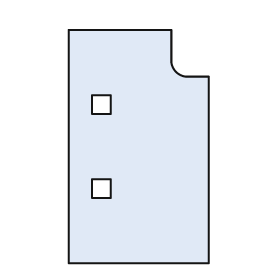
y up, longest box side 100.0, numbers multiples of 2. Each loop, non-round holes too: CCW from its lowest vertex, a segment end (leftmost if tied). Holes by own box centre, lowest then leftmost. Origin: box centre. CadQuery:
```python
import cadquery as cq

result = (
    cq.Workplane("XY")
    .moveTo(-30.0, -50.0)
    .lineTo(30.0, -50.0)
    .lineTo(30.0, 30.0)
    .lineTo(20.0, 30.0)
    .threePointArc((16.0, 32.0), (14.0, 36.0))
    .lineTo(14.0, 50.0)
    .lineTo(-30.0, 50.0)
    .close()
    .moveTo(-20.0, -22.0)
    .lineTo(-12.0, -22.0)
    .lineTo(-12.0, -14.0)
    .lineTo(-20.0, -14.0)
    .close()
    .moveTo(-20.0, 14.0)
    .lineTo(-12.0, 14.0)
    .lineTo(-12.0, 22.0)
    .lineTo(-20.0, 22.0)
    .close()
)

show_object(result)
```